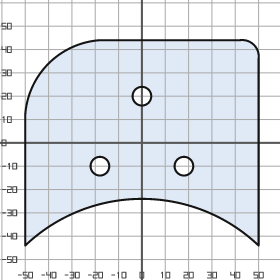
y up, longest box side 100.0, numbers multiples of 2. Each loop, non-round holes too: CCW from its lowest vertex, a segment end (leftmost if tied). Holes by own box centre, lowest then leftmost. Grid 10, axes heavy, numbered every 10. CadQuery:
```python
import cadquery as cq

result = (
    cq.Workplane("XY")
    .moveTo(-50.0, -44.0)
    .threePointArc((0.0, -24.0), (50.0, -44.0))
    .lineTo(50.0, 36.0)
    .threePointArc((48.0, 42.0), (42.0, 44.0))
    .lineTo(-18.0, 44.0)
    .threePointArc((-40.0, 34.0), (-50.0, 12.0))
    .close()
    .moveTo(-18.0, -10.0)
    .circle(4.0)
    .moveTo(18.0, -10.0)
    .circle(4.0)
    .moveTo(0.0, 20.0)
    .circle(4.0)
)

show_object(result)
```